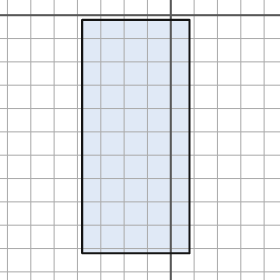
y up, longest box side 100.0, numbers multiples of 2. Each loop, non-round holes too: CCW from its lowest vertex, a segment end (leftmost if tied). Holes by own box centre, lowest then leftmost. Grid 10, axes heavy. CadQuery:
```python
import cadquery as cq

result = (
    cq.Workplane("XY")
    .moveTo(-38.0, -102.0)
    .lineTo(8.0, -102.0)
    .lineTo(8.0, -2.0)
    .lineTo(-38.0, -2.0)
    .close()
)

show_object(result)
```